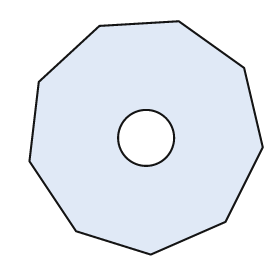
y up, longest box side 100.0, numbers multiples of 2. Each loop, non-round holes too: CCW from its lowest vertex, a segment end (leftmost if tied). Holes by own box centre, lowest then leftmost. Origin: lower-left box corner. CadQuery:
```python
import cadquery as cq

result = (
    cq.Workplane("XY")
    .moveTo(52.0, 0.0)
    .lineTo(84.0, 14.0)
    .lineTo(100.0, 46.0)
    .lineTo(92.0, 80.0)
    .lineTo(64.0, 100.0)
    .lineTo(30.0, 98.0)
    .lineTo(4.0, 74.0)
    .lineTo(0.0, 40.0)
    .lineTo(20.0, 10.0)
    .close()
    .moveTo(50.0, 50.0)
    .circle(12.0)
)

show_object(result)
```